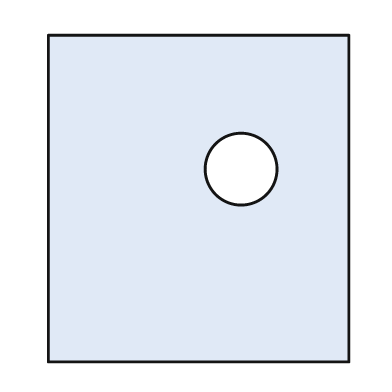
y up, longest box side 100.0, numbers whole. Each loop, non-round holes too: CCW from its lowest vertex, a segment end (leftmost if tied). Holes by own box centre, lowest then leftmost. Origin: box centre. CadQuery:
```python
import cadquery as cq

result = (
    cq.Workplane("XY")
    .moveTo(-46.0, -50.0)
    .lineTo(46.0, -50.0)
    .lineTo(46.0, 50.0)
    .lineTo(-46.0, 50.0)
    .close()
    .moveTo(13.0, 9.0)
    .circle(11.0)
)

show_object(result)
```